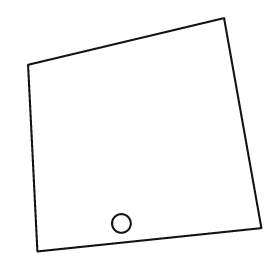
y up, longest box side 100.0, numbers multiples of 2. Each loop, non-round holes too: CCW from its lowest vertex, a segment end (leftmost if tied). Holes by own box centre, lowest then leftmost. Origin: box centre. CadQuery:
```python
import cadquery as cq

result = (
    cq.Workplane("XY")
    .moveTo(-46.0, -50.0)
    .lineTo(50.0, -40.0)
    .lineTo(34.0, 50.0)
    .lineTo(-50.0, 30.0)
    .close()
    .moveTo(-10.0, -38.0)
    .circle(4.0)
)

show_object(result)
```